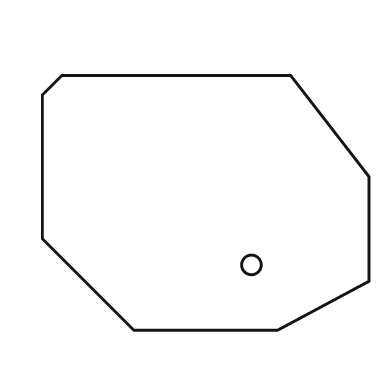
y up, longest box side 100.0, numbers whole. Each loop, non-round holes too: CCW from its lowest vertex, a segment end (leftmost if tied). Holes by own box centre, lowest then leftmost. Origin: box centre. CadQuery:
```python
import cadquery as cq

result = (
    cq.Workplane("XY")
    .moveTo(-22.0, -39.0)
    .lineTo(22.0, -39.0)
    .lineTo(50.0, -24.0)
    .lineTo(50.0, 8.0)
    .lineTo(26.0, 39.0)
    .lineTo(-44.0, 39.0)
    .lineTo(-50.0, 33.0)
    .lineTo(-50.0, -11.0)
    .close()
    .moveTo(14.0, -19.0)
    .circle(3.0)
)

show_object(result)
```